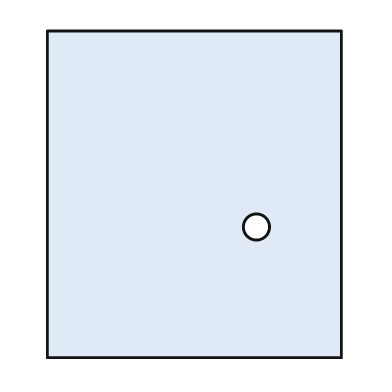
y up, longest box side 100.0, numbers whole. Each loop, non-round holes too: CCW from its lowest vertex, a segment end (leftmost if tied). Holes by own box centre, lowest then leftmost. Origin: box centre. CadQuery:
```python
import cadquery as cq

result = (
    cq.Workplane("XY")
    .moveTo(-45.0, -50.0)
    .lineTo(45.0, -50.0)
    .lineTo(45.0, 50.0)
    .lineTo(-45.0, 50.0)
    .close()
    .moveTo(19.0, -10.0)
    .circle(4.0)
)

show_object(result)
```